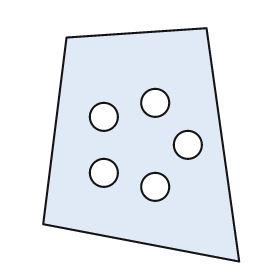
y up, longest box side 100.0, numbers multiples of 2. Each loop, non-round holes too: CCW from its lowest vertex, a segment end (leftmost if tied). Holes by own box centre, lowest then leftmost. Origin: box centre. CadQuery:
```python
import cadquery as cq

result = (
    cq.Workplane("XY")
    .moveTo(42.0, -50.0)
    .lineTo(28.0, 50.0)
    .lineTo(-32.0, 46.0)
    .lineTo(-42.0, -34.0)
    .close()
    .moveTo(6.0, -18.0)
    .circle(6.0)
    .moveTo(-16.0, -12.0)
    .circle(6.0)
    .moveTo(20.0, 0.0)
    .circle(6.0)
    .moveTo(-16.0, 12.0)
    .circle(6.0)
    .moveTo(6.0, 18.0)
    .circle(6.0)
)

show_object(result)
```